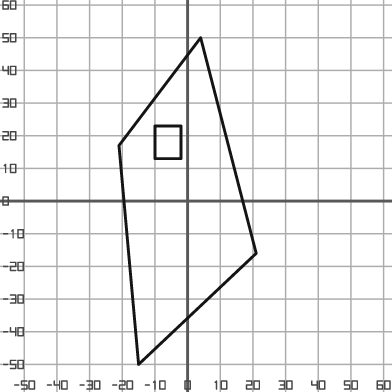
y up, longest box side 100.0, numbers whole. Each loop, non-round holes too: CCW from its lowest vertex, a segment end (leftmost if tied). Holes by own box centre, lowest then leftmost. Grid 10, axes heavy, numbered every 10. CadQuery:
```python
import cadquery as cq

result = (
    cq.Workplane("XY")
    .moveTo(-15.0, -50.0)
    .lineTo(21.0, -16.0)
    .lineTo(4.0, 50.0)
    .lineTo(-21.0, 17.0)
    .close()
    .moveTo(-10.0, 13.0)
    .lineTo(-2.0, 13.0)
    .lineTo(-2.0, 23.0)
    .lineTo(-10.0, 23.0)
    .close()
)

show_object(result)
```